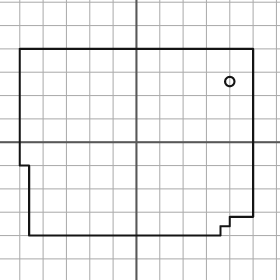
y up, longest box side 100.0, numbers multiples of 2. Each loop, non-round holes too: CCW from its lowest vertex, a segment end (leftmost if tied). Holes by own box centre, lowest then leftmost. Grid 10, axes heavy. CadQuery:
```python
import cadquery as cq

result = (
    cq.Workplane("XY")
    .moveTo(-46.0, -40.0)
    .lineTo(36.0, -40.0)
    .lineTo(36.0, -36.0)
    .lineTo(40.0, -36.0)
    .lineTo(40.0, -32.0)
    .lineTo(50.0, -32.0)
    .lineTo(50.0, 40.0)
    .lineTo(-50.0, 40.0)
    .lineTo(-50.0, -10.0)
    .lineTo(-46.0, -10.0)
    .close()
    .moveTo(40.0, 26.0)
    .circle(2.0)
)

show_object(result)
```